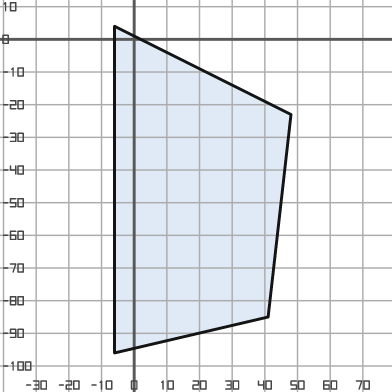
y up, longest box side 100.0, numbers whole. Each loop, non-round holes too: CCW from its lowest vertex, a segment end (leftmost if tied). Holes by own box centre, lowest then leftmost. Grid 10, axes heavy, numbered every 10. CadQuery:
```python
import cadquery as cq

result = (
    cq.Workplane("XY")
    .moveTo(-6.0, -96.0)
    .lineTo(41.0, -85.0)
    .lineTo(48.0, -23.0)
    .lineTo(-6.0, 4.0)
    .close()
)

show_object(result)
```